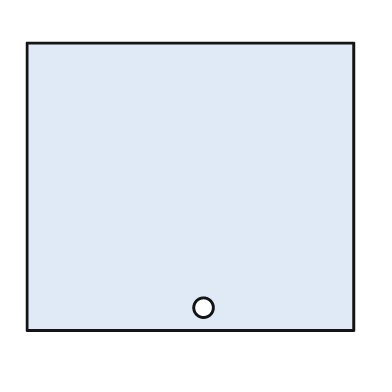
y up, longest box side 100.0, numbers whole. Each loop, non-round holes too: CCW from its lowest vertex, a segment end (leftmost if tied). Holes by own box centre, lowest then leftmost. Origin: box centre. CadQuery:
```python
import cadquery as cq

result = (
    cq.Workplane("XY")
    .moveTo(-50.0, -44.0)
    .lineTo(50.0, -44.0)
    .lineTo(50.0, 44.0)
    .lineTo(-50.0, 44.0)
    .close()
    .moveTo(4.0, -37.0)
    .circle(3.0)
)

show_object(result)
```